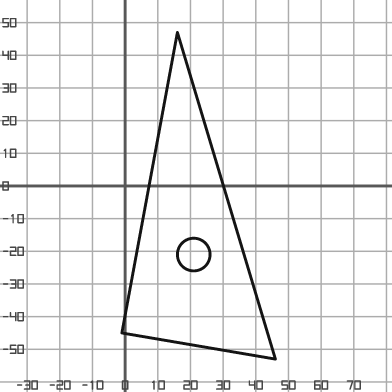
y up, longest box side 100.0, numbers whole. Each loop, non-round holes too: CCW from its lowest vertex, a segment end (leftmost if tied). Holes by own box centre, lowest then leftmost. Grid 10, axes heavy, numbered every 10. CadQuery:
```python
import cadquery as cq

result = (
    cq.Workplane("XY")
    .moveTo(46.0, -53.0)
    .lineTo(16.0, 47.0)
    .lineTo(-1.0, -45.0)
    .close()
    .moveTo(21.0, -21.0)
    .circle(5.0)
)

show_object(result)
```